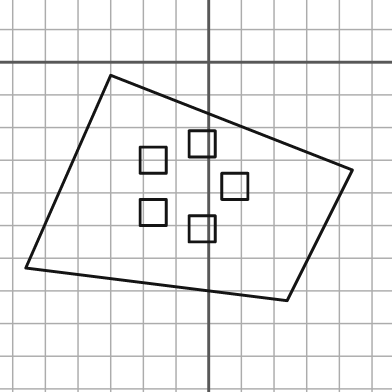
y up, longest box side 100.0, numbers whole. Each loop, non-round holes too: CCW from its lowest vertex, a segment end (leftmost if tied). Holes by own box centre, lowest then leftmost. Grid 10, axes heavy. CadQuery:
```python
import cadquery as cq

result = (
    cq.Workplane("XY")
    .moveTo(24.0, -73.0)
    .lineTo(44.0, -33.0)
    .lineTo(-30.0, -4.0)
    .lineTo(-56.0, -63.0)
    .close()
    .moveTo(-6.0, -55.0)
    .lineTo(2.0, -55.0)
    .lineTo(2.0, -47.0)
    .lineTo(-6.0, -47.0)
    .close()
    .moveTo(-21.0, -50.0)
    .lineTo(-13.0, -50.0)
    .lineTo(-13.0, -42.0)
    .lineTo(-21.0, -42.0)
    .close()
    .moveTo(4.0, -42.0)
    .lineTo(12.0, -42.0)
    .lineTo(12.0, -34.0)
    .lineTo(4.0, -34.0)
    .close()
    .moveTo(-21.0, -34.0)
    .lineTo(-13.0, -34.0)
    .lineTo(-13.0, -26.0)
    .lineTo(-21.0, -26.0)
    .close()
    .moveTo(-6.0, -29.0)
    .lineTo(2.0, -29.0)
    .lineTo(2.0, -21.0)
    .lineTo(-6.0, -21.0)
    .close()
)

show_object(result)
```